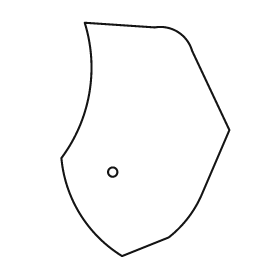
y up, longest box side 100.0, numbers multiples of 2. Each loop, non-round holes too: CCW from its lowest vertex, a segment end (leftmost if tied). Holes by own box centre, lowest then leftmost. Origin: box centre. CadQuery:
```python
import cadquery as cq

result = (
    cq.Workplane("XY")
    .moveTo(-10.0, -50.0)
    .lineTo(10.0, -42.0)
    .threePointArc((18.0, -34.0), (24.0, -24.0))
    .lineTo(36.0, 4.0)
    .lineTo(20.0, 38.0)
    .threePointArc((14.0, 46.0), (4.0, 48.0))
    .lineTo(-26.0, 50.0)
    .threePointArc((-24.0, 20.0), (-36.0, -8.0))
    .threePointArc((-28.0, -32.0), (-10.0, -50.0))
    .close()
    .moveTo(-14.0, -14.0)
    .circle(2.0)
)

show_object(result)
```